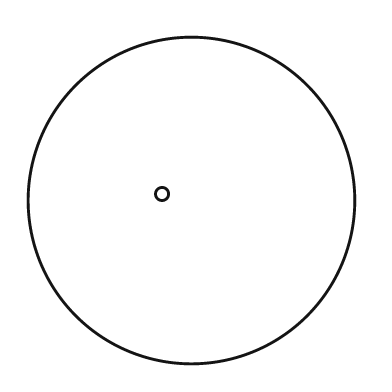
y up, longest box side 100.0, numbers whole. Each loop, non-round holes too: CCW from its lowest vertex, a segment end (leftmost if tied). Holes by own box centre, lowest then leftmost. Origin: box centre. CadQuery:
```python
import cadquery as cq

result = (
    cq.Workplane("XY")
    .moveTo(0.0, 0.0)
    .circle(50.0)
    .moveTo(-9.0, 2.0)
    .circle(2.0)
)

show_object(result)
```